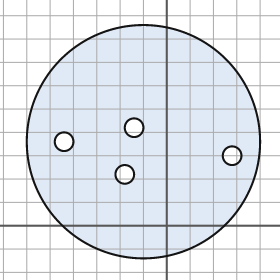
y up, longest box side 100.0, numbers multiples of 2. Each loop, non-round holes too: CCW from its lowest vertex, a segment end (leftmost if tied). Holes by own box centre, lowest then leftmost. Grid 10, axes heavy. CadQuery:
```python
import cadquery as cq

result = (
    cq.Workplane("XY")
    .moveTo(-10.0, 36.0)
    .circle(50.0)
    .moveTo(-18.0, 22.0)
    .circle(4.0)
    .moveTo(28.0, 30.0)
    .circle(4.0)
    .moveTo(-44.0, 36.0)
    .circle(4.0)
    .moveTo(-14.0, 42.0)
    .circle(4.0)
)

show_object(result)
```